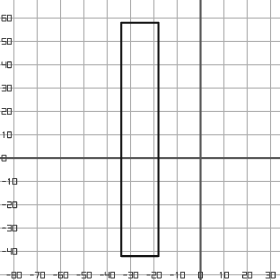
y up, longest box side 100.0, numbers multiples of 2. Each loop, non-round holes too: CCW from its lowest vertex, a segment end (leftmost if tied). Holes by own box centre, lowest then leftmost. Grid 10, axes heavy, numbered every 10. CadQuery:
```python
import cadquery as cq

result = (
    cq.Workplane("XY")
    .moveTo(-34.0, -42.0)
    .lineTo(-18.0, -42.0)
    .lineTo(-18.0, 58.0)
    .lineTo(-34.0, 58.0)
    .close()
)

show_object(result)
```